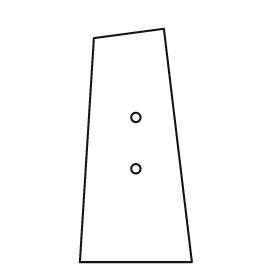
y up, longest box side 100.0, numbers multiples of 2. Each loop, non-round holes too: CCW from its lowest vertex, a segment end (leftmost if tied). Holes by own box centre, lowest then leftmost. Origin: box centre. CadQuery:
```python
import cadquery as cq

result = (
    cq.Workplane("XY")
    .moveTo(-24.0, -50.0)
    .lineTo(24.0, -50.0)
    .lineTo(12.0, 50.0)
    .lineTo(-18.0, 46.0)
    .close()
    .moveTo(0.0, -10.0)
    .circle(2.0)
    .moveTo(0.0, 12.0)
    .circle(2.0)
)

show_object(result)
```